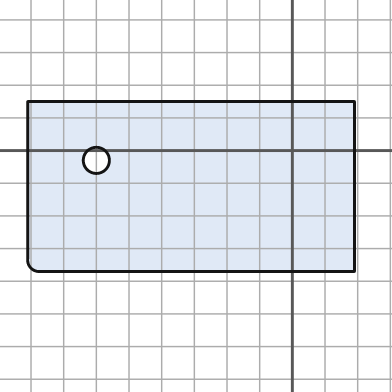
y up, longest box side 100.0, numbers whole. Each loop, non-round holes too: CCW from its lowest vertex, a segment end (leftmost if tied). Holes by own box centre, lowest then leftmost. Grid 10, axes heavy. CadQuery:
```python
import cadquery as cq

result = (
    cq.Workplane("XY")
    .moveTo(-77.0, -37.0)
    .lineTo(19.0, -37.0)
    .lineTo(19.0, 15.0)
    .lineTo(-81.0, 15.0)
    .lineTo(-81.0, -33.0)
    .threePointArc((-80.0, -36.0), (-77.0, -37.0))
    .close()
    .moveTo(-60.0, -3.0)
    .circle(4.0)
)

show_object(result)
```